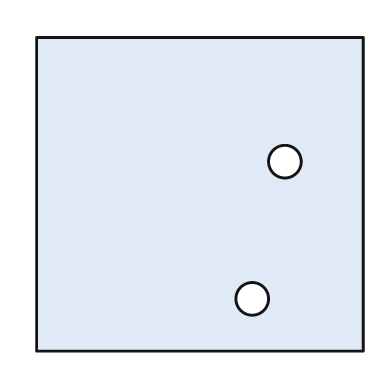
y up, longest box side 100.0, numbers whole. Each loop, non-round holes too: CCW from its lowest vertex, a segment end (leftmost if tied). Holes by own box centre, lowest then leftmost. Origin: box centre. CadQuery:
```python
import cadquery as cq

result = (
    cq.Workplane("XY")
    .moveTo(-50.0, -48.0)
    .lineTo(50.0, -48.0)
    .lineTo(50.0, 48.0)
    .lineTo(-50.0, 48.0)
    .close()
    .moveTo(16.0, -32.0)
    .circle(5.0)
    .moveTo(26.0, 10.0)
    .circle(5.0)
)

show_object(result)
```